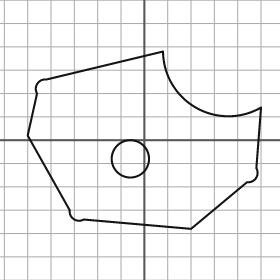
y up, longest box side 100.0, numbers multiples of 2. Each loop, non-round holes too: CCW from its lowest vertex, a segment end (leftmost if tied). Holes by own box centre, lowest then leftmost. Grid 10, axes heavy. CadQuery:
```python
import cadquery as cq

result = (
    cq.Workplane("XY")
    .moveTo(20.0, -38.0)
    .lineTo(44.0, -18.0)
    .threePointArc((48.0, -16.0), (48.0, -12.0))
    .lineTo(50.0, 14.0)
    .threePointArc((22.0, 14.0), (8.0, 38.0))
    .lineTo(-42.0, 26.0)
    .threePointArc((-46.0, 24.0), (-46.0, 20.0))
    .lineTo(-50.0, 2.0)
    .lineTo(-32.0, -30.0)
    .threePointArc((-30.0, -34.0), (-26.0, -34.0))
    .close()
    .moveTo(-6.0, -8.0)
    .circle(8.0)
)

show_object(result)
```